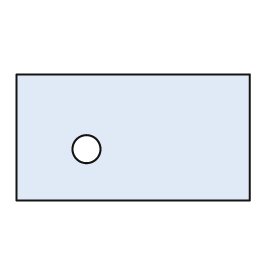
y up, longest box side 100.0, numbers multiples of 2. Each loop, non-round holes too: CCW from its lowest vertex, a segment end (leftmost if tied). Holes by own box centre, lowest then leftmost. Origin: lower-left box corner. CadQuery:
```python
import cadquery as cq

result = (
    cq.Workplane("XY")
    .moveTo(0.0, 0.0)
    .lineTo(100.0, 0.0)
    .lineTo(100.0, 54.0)
    .lineTo(0.0, 54.0)
    .close()
    .moveTo(30.0, 22.0)
    .circle(6.0)
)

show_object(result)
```